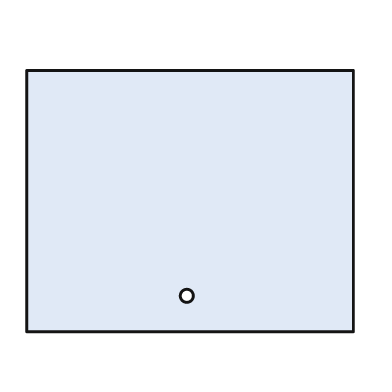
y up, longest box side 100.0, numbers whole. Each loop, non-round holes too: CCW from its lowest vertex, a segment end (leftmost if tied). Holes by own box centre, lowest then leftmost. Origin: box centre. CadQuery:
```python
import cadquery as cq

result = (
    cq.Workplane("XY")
    .moveTo(-50.0, -40.0)
    .lineTo(50.0, -40.0)
    .lineTo(50.0, 40.0)
    .lineTo(-50.0, 40.0)
    .close()
    .moveTo(-1.0, -29.0)
    .circle(2.0)
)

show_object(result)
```